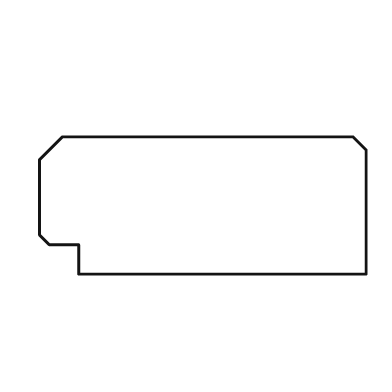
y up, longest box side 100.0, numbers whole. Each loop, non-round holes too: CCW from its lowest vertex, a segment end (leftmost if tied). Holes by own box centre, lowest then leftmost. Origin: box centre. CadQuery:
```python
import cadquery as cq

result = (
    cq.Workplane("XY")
    .moveTo(-38.0, -21.0)
    .lineTo(50.0, -21.0)
    .lineTo(50.0, 17.0)
    .lineTo(46.0, 21.0)
    .lineTo(-43.0, 21.0)
    .lineTo(-50.0, 14.0)
    .lineTo(-50.0, -9.0)
    .lineTo(-47.0, -12.0)
    .lineTo(-38.0, -12.0)
    .close()
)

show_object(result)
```